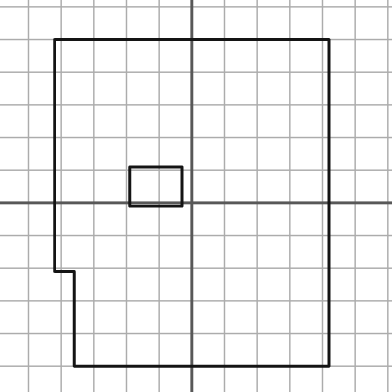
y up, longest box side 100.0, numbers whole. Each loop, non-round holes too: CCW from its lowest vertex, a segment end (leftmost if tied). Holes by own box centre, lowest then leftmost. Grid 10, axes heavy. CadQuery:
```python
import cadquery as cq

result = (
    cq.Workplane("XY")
    .moveTo(-36.0, -50.0)
    .lineTo(42.0, -50.0)
    .lineTo(42.0, 50.0)
    .lineTo(-42.0, 50.0)
    .lineTo(-42.0, -21.0)
    .lineTo(-36.0, -21.0)
    .close()
    .moveTo(-19.0, -1.0)
    .lineTo(-3.0, -1.0)
    .lineTo(-3.0, 11.0)
    .lineTo(-19.0, 11.0)
    .close()
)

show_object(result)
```